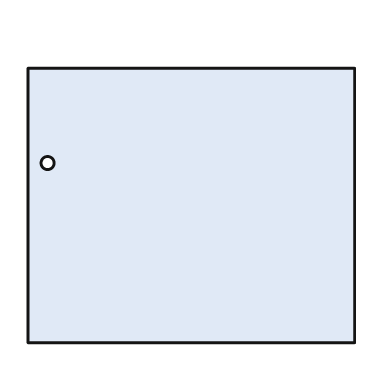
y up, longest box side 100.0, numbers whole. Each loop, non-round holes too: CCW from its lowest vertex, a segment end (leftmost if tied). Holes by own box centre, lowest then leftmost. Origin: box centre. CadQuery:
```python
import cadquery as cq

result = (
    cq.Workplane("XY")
    .moveTo(-50.0, -42.0)
    .lineTo(50.0, -42.0)
    .lineTo(50.0, 42.0)
    .lineTo(-50.0, 42.0)
    .close()
    .moveTo(-44.0, 13.0)
    .circle(2.0)
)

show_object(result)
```